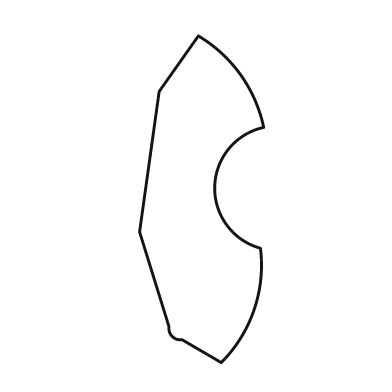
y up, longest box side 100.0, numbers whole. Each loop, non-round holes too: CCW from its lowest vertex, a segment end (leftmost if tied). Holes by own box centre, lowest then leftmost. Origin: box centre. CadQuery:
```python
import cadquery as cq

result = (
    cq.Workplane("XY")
    .moveTo(6.0, -50.0)
    .threePointArc((16.0, -34.0), (18.0, -15.0))
    .threePointArc((4.0, 4.0), (19.0, 22.0))
    .threePointArc((12.0, 38.0), (-1.0, 50.0))
    .lineTo(-13.0, 33.0)
    .lineTo(-19.0, -10.0)
    .lineTo(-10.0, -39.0)
    .threePointArc((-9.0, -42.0), (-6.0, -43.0))
    .close()
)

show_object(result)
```